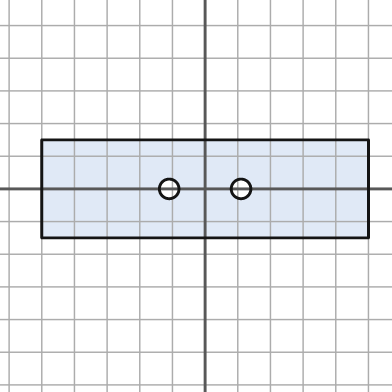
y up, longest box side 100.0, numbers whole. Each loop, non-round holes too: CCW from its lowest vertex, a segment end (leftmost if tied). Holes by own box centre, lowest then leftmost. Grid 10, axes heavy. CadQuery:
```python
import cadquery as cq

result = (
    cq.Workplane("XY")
    .moveTo(-50.0, -15.0)
    .lineTo(50.0, -15.0)
    .lineTo(50.0, 15.0)
    .lineTo(-50.0, 15.0)
    .close()
    .moveTo(-11.0, 0.0)
    .circle(3.0)
    .moveTo(11.0, 0.0)
    .circle(3.0)
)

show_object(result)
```